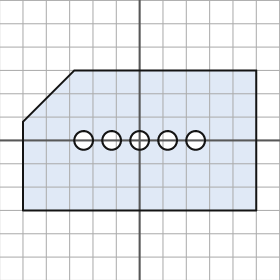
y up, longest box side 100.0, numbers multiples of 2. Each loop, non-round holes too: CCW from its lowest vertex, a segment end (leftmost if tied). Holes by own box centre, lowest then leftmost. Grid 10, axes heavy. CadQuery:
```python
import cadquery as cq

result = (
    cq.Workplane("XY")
    .moveTo(-50.0, -30.0)
    .lineTo(50.0, -30.0)
    .lineTo(50.0, 30.0)
    .lineTo(-28.0, 30.0)
    .lineTo(-50.0, 8.0)
    .close()
    .moveTo(-24.0, 0.0)
    .circle(4.0)
    .moveTo(-12.0, 0.0)
    .circle(4.0)
    .moveTo(0.0, 0.0)
    .circle(4.0)
    .moveTo(12.0, 0.0)
    .circle(4.0)
    .moveTo(24.0, 0.0)
    .circle(4.0)
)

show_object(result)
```